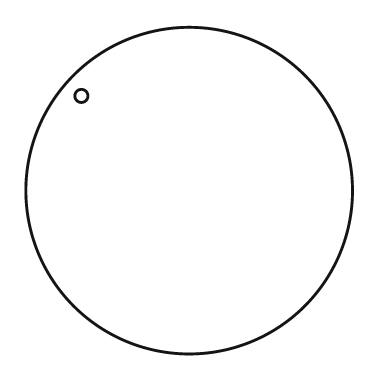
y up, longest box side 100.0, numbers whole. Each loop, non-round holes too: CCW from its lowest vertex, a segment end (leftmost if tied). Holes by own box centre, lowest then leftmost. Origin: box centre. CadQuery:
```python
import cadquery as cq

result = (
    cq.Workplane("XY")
    .moveTo(0.0, 0.0)
    .circle(50.0)
    .moveTo(-33.0, 29.0)
    .circle(2.0)
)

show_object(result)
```